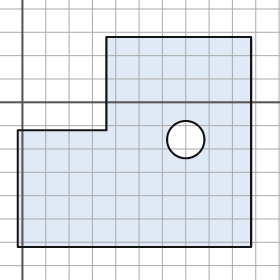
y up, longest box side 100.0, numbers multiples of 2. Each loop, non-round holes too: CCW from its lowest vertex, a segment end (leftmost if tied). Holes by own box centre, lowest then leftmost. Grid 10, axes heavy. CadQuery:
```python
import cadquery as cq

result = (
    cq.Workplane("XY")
    .moveTo(-2.0, -62.0)
    .lineTo(98.0, -62.0)
    .lineTo(98.0, 28.0)
    .lineTo(36.0, 28.0)
    .lineTo(36.0, -12.0)
    .lineTo(-2.0, -12.0)
    .close()
    .moveTo(70.0, -16.0)
    .circle(8.0)
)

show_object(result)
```